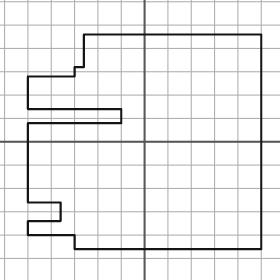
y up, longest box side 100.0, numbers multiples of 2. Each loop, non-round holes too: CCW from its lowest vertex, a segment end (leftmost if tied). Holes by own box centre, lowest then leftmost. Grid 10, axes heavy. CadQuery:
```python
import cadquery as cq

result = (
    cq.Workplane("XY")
    .moveTo(-30.0, -46.0)
    .lineTo(50.0, -46.0)
    .lineTo(50.0, 46.0)
    .lineTo(-26.0, 46.0)
    .lineTo(-26.0, 32.0)
    .lineTo(-30.0, 32.0)
    .lineTo(-30.0, 28.0)
    .lineTo(-50.0, 28.0)
    .lineTo(-50.0, 14.0)
    .lineTo(-10.0, 14.0)
    .lineTo(-10.0, 8.0)
    .lineTo(-50.0, 8.0)
    .lineTo(-50.0, -26.0)
    .lineTo(-36.0, -26.0)
    .lineTo(-36.0, -34.0)
    .lineTo(-50.0, -34.0)
    .lineTo(-50.0, -40.0)
    .lineTo(-30.0, -40.0)
    .close()
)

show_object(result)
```